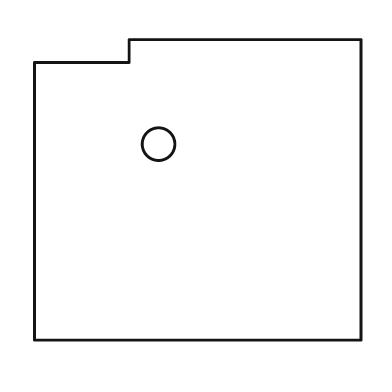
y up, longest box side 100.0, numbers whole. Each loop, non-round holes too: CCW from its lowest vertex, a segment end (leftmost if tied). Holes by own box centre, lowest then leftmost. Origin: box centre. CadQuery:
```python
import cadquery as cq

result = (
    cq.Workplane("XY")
    .moveTo(-50.0, -46.0)
    .lineTo(50.0, -46.0)
    .lineTo(50.0, 46.0)
    .lineTo(-21.0, 46.0)
    .lineTo(-21.0, 39.0)
    .lineTo(-50.0, 39.0)
    .close()
    .moveTo(-12.0, 14.0)
    .circle(5.0)
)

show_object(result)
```